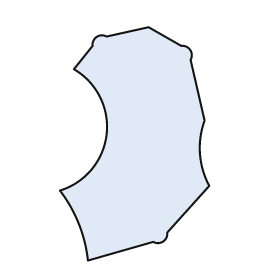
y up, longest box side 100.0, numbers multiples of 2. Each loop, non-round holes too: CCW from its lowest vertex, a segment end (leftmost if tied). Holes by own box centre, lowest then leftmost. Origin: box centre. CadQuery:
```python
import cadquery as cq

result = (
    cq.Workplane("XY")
    .moveTo(-20.0, -50.0)
    .lineTo(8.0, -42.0)
    .threePointArc((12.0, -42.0), (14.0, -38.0))
    .lineTo(32.0, -18.0)
    .threePointArc((28.0, -4.0), (30.0, 10.0))
    .lineTo(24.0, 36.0)
    .threePointArc((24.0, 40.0), (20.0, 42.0))
    .lineTo(6.0, 50.0)
    .lineTo(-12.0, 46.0)
    .threePointArc((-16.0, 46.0), (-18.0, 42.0))
    .lineTo(-26.0, 32.0)
    .threePointArc((-12.0, 4.0), (-32.0, -20.0))
    .threePointArc((-24.0, -34.0), (-20.0, -50.0))
    .close()
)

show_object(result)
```